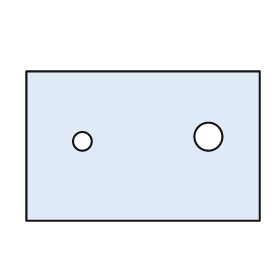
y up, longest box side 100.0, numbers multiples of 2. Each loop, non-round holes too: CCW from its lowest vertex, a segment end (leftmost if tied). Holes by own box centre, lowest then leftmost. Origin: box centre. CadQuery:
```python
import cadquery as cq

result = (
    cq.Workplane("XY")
    .moveTo(-50.0, -32.0)
    .lineTo(50.0, -32.0)
    .lineTo(50.0, 32.0)
    .lineTo(-50.0, 32.0)
    .close()
    .moveTo(-26.0, 2.0)
    .circle(4.0)
    .moveTo(28.0, 4.0)
    .circle(6.0)
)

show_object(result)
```